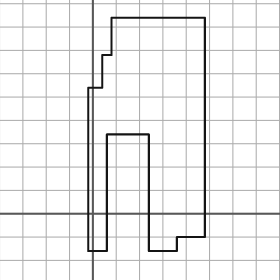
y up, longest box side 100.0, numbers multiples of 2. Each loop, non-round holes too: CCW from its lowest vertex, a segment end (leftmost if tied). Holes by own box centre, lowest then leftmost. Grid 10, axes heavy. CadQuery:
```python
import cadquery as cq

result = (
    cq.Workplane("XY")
    .moveTo(-2.0, -16.0)
    .lineTo(6.0, -16.0)
    .lineTo(6.0, 34.0)
    .lineTo(24.0, 34.0)
    .lineTo(24.0, -16.0)
    .lineTo(36.0, -16.0)
    .lineTo(36.0, -10.0)
    .lineTo(48.0, -10.0)
    .lineTo(48.0, 84.0)
    .lineTo(8.0, 84.0)
    .lineTo(8.0, 68.0)
    .lineTo(4.0, 68.0)
    .lineTo(4.0, 54.0)
    .lineTo(-2.0, 54.0)
    .close()
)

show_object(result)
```